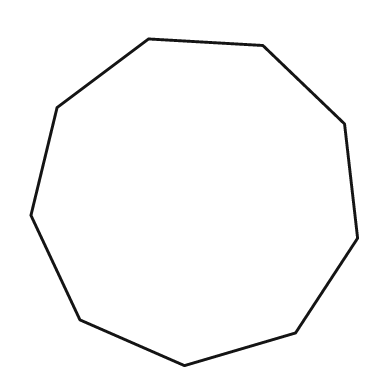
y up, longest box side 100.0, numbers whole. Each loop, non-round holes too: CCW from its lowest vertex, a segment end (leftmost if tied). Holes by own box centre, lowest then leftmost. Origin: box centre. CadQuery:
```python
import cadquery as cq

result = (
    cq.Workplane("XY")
    .moveTo(-3.0, -50.0)
    .lineTo(31.0, -40.0)
    .lineTo(50.0, -11.0)
    .lineTo(46.0, 24.0)
    .lineTo(21.0, 48.0)
    .lineTo(-14.0, 50.0)
    .lineTo(-42.0, 29.0)
    .lineTo(-50.0, -4.0)
    .lineTo(-35.0, -36.0)
    .close()
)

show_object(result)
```